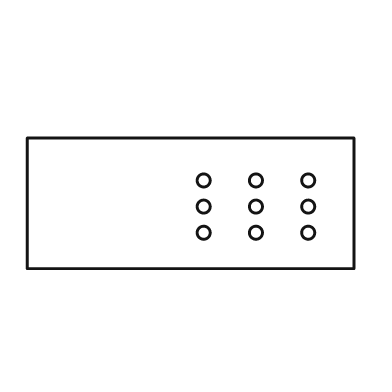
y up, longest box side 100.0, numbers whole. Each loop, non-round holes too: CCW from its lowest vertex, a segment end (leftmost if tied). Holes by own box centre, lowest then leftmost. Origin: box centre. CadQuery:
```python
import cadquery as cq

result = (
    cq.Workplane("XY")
    .moveTo(-50.0, -20.0)
    .lineTo(50.0, -20.0)
    .lineTo(50.0, 20.0)
    .lineTo(-50.0, 20.0)
    .close()
    .moveTo(4.0, -9.0)
    .circle(2.0)
    .moveTo(20.0, -9.0)
    .circle(2.0)
    .moveTo(36.0, -9.0)
    .circle(2.0)
    .moveTo(4.0, -1.0)
    .circle(2.0)
    .moveTo(20.0, -1.0)
    .circle(2.0)
    .moveTo(36.0, -1.0)
    .circle(2.0)
    .moveTo(4.0, 7.0)
    .circle(2.0)
    .moveTo(20.0, 7.0)
    .circle(2.0)
    .moveTo(36.0, 7.0)
    .circle(2.0)
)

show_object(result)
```